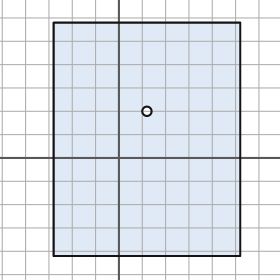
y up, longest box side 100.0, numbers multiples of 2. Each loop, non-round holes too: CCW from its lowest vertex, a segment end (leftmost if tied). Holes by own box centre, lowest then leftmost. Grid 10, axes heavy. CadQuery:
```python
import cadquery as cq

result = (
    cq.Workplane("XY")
    .moveTo(-28.0, -42.0)
    .lineTo(52.0, -42.0)
    .lineTo(52.0, 58.0)
    .lineTo(-28.0, 58.0)
    .close()
    .moveTo(12.0, 20.0)
    .circle(2.0)
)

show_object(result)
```